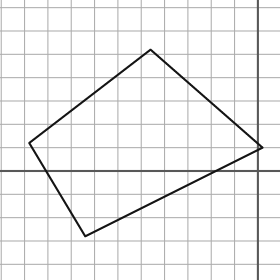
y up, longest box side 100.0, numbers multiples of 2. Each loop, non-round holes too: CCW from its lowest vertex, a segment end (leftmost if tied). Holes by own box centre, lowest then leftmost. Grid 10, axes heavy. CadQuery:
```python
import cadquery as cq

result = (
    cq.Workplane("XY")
    .moveTo(-74.0, -28.0)
    .lineTo(2.0, 10.0)
    .lineTo(-46.0, 52.0)
    .lineTo(-98.0, 12.0)
    .close()
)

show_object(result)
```